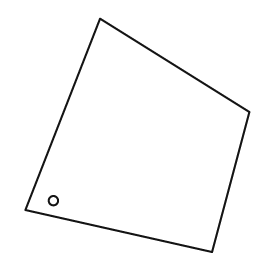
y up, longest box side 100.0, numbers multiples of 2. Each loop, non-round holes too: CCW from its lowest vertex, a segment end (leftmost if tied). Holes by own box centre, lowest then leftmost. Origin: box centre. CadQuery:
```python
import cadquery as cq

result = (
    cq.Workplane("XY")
    .moveTo(32.0, -50.0)
    .lineTo(48.0, 10.0)
    .lineTo(-16.0, 50.0)
    .lineTo(-48.0, -32.0)
    .close()
    .moveTo(-36.0, -28.0)
    .circle(2.0)
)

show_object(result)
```